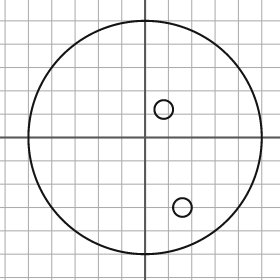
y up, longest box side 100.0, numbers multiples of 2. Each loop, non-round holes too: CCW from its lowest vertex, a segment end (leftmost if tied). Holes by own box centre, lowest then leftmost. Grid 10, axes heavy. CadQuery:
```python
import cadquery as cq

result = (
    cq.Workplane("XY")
    .moveTo(0.0, 0.0)
    .circle(50.0)
    .moveTo(16.0, -30.0)
    .circle(4.0)
    .moveTo(8.0, 12.0)
    .circle(4.0)
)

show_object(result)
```